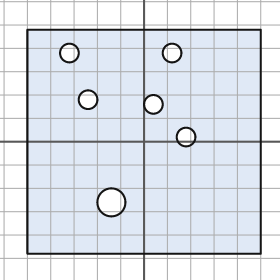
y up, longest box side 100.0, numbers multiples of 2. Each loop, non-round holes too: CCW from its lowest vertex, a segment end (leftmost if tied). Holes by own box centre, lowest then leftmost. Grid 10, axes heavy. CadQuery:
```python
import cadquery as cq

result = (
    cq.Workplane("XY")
    .moveTo(-50.0, -48.0)
    .lineTo(50.0, -48.0)
    .lineTo(50.0, 48.0)
    .lineTo(-50.0, 48.0)
    .close()
    .moveTo(-14.0, -26.0)
    .circle(6.0)
    .moveTo(18.0, 2.0)
    .circle(4.0)
    .moveTo(4.0, 16.0)
    .circle(4.0)
    .moveTo(-24.0, 18.0)
    .circle(4.0)
    .moveTo(-32.0, 38.0)
    .circle(4.0)
    .moveTo(12.0, 38.0)
    .circle(4.0)
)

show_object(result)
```